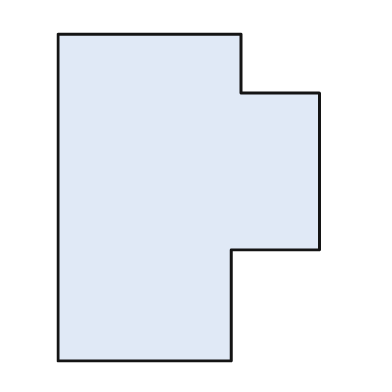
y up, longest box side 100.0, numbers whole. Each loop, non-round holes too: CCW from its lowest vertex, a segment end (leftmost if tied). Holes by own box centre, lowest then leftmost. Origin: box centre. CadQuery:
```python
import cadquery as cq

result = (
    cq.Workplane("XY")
    .moveTo(-40.0, -50.0)
    .lineTo(13.0, -50.0)
    .lineTo(13.0, -16.0)
    .lineTo(40.0, -16.0)
    .lineTo(40.0, 32.0)
    .lineTo(16.0, 32.0)
    .lineTo(16.0, 50.0)
    .lineTo(-40.0, 50.0)
    .close()
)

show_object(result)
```